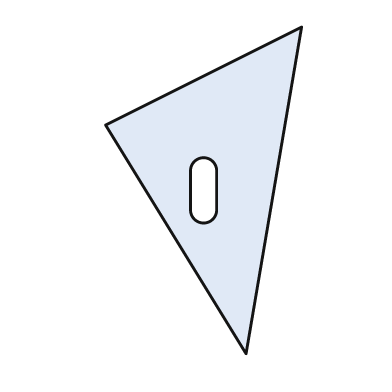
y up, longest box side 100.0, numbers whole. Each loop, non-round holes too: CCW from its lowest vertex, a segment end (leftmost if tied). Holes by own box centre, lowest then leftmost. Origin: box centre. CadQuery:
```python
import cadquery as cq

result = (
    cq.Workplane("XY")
    .moveTo(13.0, -50.0)
    .lineTo(30.0, 50.0)
    .lineTo(-30.0, 20.0)
    .close()
    .moveTo(-4.0, -6.0)
    .threePointArc((0.0, -10.0), (4.0, -6.0))
    .lineTo(4.0, 6.0)
    .threePointArc((0.0, 10.0), (-4.0, 6.0))
    .close()
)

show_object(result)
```